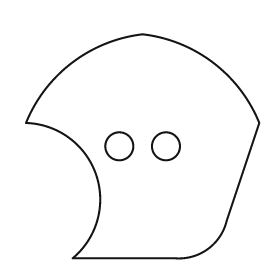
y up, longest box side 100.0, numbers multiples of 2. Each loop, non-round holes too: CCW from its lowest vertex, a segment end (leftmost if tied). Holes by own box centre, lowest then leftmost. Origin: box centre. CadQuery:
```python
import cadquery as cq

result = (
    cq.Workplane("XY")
    .moveTo(-30.0, -48.0)
    .lineTo(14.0, -48.0)
    .threePointArc((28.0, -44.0), (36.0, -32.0))
    .lineTo(50.0, 10.0)
    .threePointArc((30.0, 36.0), (0.0, 48.0))
    .threePointArc((-30.0, 36.0), (-50.0, 10.0))
    .threePointArc((-20.0, -12.0), (-30.0, -48.0))
    .close()
    .moveTo(-10.0, 0.0)
    .circle(6.0)
    .moveTo(10.0, 0.0)
    .circle(6.0)
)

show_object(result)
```